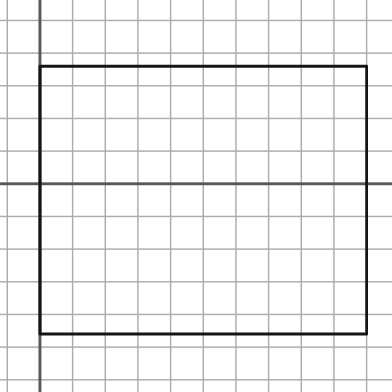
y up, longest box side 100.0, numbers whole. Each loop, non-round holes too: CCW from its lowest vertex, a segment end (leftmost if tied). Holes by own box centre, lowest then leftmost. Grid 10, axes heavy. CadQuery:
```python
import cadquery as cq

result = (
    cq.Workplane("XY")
    .moveTo(0.0, -46.0)
    .lineTo(100.0, -46.0)
    .lineTo(100.0, 36.0)
    .lineTo(0.0, 36.0)
    .close()
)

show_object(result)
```